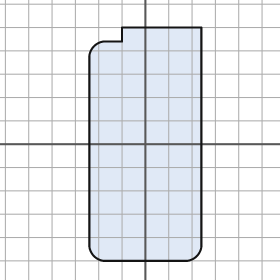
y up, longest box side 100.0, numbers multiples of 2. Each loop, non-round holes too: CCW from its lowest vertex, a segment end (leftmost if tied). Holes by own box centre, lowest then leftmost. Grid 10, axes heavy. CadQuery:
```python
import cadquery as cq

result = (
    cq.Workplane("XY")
    .moveTo(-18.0, -50.0)
    .lineTo(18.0, -50.0)
    .threePointArc((22.0, -48.0), (24.0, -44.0))
    .lineTo(24.0, 50.0)
    .lineTo(-10.0, 50.0)
    .lineTo(-10.0, 44.0)
    .lineTo(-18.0, 44.0)
    .threePointArc((-22.0, 42.0), (-24.0, 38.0))
    .lineTo(-24.0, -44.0)
    .threePointArc((-22.0, -48.0), (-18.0, -50.0))
    .close()
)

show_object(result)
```